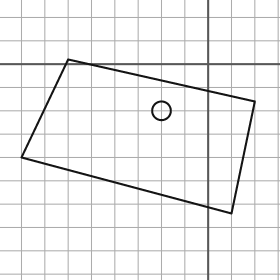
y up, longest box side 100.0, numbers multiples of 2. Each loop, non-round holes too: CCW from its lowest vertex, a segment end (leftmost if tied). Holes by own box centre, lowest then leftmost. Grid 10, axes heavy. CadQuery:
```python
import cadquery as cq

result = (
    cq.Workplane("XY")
    .moveTo(10.0, -64.0)
    .lineTo(20.0, -16.0)
    .lineTo(-60.0, 2.0)
    .lineTo(-80.0, -40.0)
    .close()
    .moveTo(-20.0, -20.0)
    .circle(4.0)
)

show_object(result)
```